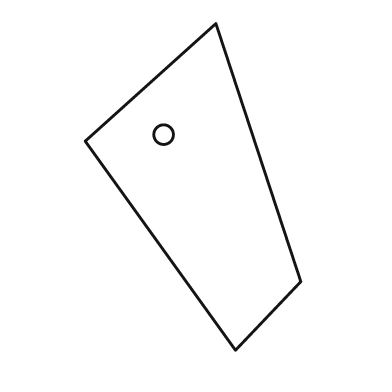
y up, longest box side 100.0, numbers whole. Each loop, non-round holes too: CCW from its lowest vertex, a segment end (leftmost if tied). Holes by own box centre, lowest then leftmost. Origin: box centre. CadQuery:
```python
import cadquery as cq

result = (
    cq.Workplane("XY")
    .moveTo(13.0, -50.0)
    .lineTo(33.0, -29.0)
    .lineTo(7.0, 50.0)
    .lineTo(-33.0, 14.0)
    .close()
    .moveTo(-9.0, 16.0)
    .circle(3.0)
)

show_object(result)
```